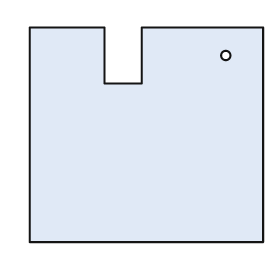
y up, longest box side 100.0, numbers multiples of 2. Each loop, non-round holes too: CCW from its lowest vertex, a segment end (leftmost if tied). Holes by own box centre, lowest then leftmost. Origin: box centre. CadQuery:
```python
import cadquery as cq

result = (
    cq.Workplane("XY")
    .moveTo(-50.0, -46.0)
    .lineTo(50.0, -46.0)
    .lineTo(50.0, 46.0)
    .lineTo(-2.0, 46.0)
    .lineTo(-2.0, 22.0)
    .lineTo(-18.0, 22.0)
    .lineTo(-18.0, 46.0)
    .lineTo(-50.0, 46.0)
    .close()
    .moveTo(34.0, 34.0)
    .circle(2.0)
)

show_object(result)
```